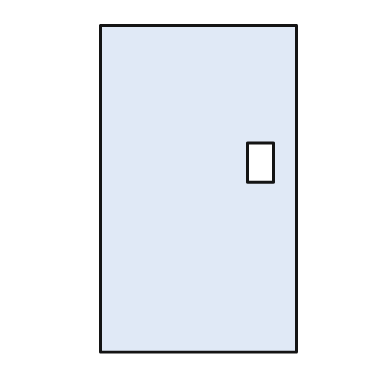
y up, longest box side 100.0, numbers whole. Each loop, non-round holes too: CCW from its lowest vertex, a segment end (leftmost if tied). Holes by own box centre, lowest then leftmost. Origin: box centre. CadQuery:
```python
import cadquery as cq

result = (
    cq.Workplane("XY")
    .moveTo(-30.0, -50.0)
    .lineTo(30.0, -50.0)
    .lineTo(30.0, 50.0)
    .lineTo(-30.0, 50.0)
    .close()
    .moveTo(15.0, 2.0)
    .lineTo(23.0, 2.0)
    .lineTo(23.0, 14.0)
    .lineTo(15.0, 14.0)
    .close()
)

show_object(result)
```